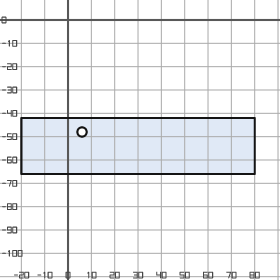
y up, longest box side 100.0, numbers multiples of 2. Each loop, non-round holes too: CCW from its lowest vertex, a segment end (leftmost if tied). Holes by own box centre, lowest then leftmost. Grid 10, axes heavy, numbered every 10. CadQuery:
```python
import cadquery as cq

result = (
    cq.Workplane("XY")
    .moveTo(-20.0, -66.0)
    .lineTo(80.0, -66.0)
    .lineTo(80.0, -42.0)
    .lineTo(-20.0, -42.0)
    .close()
    .moveTo(6.0, -48.0)
    .circle(2.0)
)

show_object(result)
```